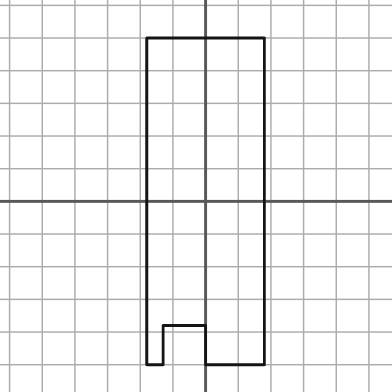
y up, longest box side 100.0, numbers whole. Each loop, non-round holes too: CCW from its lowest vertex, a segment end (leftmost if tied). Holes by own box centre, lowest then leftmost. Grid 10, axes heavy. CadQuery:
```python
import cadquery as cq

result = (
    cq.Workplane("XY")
    .moveTo(-18.0, -50.0)
    .lineTo(-13.0, -50.0)
    .lineTo(-13.0, -38.0)
    .lineTo(0.0, -38.0)
    .lineTo(0.0, -50.0)
    .lineTo(18.0, -50.0)
    .lineTo(18.0, 50.0)
    .lineTo(-18.0, 50.0)
    .close()
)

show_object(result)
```